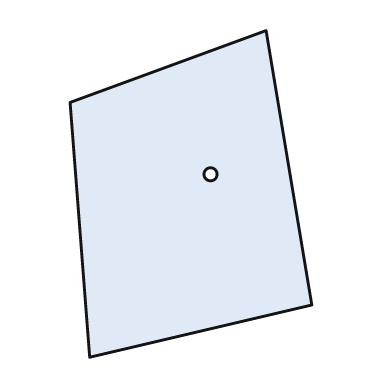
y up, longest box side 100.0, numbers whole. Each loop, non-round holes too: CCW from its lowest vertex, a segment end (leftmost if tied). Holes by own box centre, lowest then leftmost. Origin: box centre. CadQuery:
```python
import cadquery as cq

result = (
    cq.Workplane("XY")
    .moveTo(-31.0, -50.0)
    .lineTo(37.0, -34.0)
    .lineTo(23.0, 50.0)
    .lineTo(-37.0, 28.0)
    .close()
    .moveTo(6.0, 6.0)
    .circle(2.0)
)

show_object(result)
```